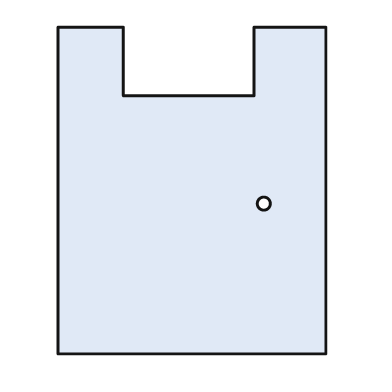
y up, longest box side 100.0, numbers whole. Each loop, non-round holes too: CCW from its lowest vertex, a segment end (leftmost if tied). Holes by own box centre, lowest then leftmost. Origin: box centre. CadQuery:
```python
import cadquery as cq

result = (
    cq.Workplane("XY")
    .moveTo(-41.0, -50.0)
    .lineTo(41.0, -50.0)
    .lineTo(41.0, 50.0)
    .lineTo(19.0, 50.0)
    .lineTo(19.0, 29.0)
    .lineTo(-21.0, 29.0)
    .lineTo(-21.0, 50.0)
    .lineTo(-41.0, 50.0)
    .close()
    .moveTo(22.0, -4.0)
    .circle(2.0)
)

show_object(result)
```